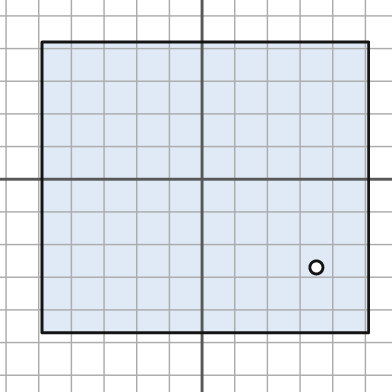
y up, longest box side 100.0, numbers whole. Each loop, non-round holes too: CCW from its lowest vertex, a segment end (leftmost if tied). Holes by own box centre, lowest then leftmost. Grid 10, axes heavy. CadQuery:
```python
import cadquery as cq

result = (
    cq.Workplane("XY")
    .moveTo(-49.0, -47.0)
    .lineTo(51.0, -47.0)
    .lineTo(51.0, 42.0)
    .lineTo(-49.0, 42.0)
    .close()
    .moveTo(35.0, -27.0)
    .circle(2.0)
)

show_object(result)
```